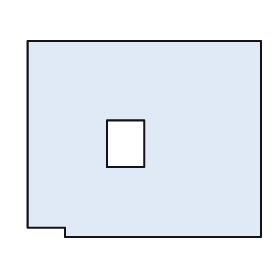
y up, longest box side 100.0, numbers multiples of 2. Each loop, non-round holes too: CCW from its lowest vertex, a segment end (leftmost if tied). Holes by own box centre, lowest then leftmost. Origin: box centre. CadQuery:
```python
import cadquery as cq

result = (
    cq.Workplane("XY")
    .moveTo(-34.0, -42.0)
    .lineTo(50.0, -42.0)
    .lineTo(50.0, 42.0)
    .lineTo(-50.0, 42.0)
    .lineTo(-50.0, -38.0)
    .lineTo(-34.0, -38.0)
    .close()
    .moveTo(-16.0, -12.0)
    .lineTo(0.0, -12.0)
    .lineTo(0.0, 8.0)
    .lineTo(-16.0, 8.0)
    .close()
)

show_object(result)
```